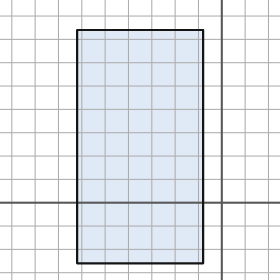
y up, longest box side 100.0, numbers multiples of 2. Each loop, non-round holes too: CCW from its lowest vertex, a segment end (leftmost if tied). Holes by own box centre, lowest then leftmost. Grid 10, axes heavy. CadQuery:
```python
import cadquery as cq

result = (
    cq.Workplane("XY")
    .moveTo(-62.0, -26.0)
    .lineTo(-8.0, -26.0)
    .lineTo(-8.0, 74.0)
    .lineTo(-62.0, 74.0)
    .close()
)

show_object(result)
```